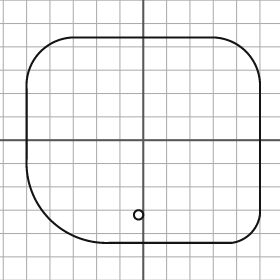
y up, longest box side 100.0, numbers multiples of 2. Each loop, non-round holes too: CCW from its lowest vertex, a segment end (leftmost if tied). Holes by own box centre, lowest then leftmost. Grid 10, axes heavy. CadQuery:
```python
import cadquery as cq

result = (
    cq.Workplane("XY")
    .moveTo(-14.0, -44.0)
    .lineTo(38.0, -44.0)
    .threePointArc((46.0, -40.0), (50.0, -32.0))
    .lineTo(50.0, 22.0)
    .threePointArc((44.0, 38.0), (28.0, 44.0))
    .lineTo(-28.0, 44.0)
    .threePointArc((-44.0, 38.0), (-50.0, 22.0))
    .lineTo(-50.0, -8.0)
    .threePointArc((-40.0, -34.0), (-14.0, -44.0))
    .close()
    .moveTo(-2.0, -32.0)
    .circle(2.0)
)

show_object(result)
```